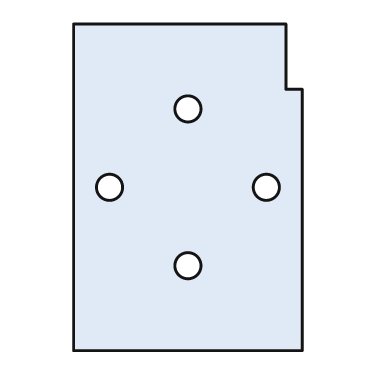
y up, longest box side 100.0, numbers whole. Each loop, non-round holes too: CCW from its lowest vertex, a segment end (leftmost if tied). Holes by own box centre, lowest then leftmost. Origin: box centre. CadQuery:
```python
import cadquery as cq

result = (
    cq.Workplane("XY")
    .moveTo(-35.0, -50.0)
    .lineTo(35.0, -50.0)
    .lineTo(35.0, 30.0)
    .lineTo(30.0, 30.0)
    .lineTo(30.0, 50.0)
    .lineTo(-35.0, 50.0)
    .close()
    .moveTo(0.0, -24.0)
    .circle(4.0)
    .moveTo(-24.0, 0.0)
    .circle(4.0)
    .moveTo(24.0, 0.0)
    .circle(4.0)
    .moveTo(0.0, 24.0)
    .circle(4.0)
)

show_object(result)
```